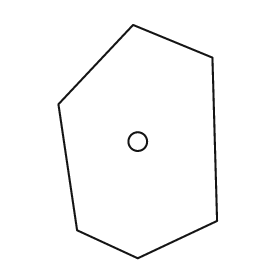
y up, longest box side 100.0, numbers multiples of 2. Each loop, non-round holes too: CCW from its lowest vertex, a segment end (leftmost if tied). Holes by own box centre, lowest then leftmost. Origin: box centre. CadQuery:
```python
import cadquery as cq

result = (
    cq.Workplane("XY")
    .moveTo(0.0, -50.0)
    .lineTo(34.0, -34.0)
    .lineTo(32.0, 36.0)
    .lineTo(-2.0, 50.0)
    .lineTo(-34.0, 16.0)
    .lineTo(-26.0, -38.0)
    .close()
    .moveTo(0.0, 0.0)
    .circle(4.0)
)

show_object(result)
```